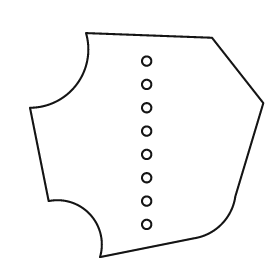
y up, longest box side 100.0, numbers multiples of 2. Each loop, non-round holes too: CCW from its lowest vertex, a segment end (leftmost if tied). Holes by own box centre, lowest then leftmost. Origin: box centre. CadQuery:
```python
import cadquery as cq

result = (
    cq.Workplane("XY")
    .moveTo(-20.0, -48.0)
    .lineTo(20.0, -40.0)
    .threePointArc((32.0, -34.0), (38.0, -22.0))
    .lineTo(50.0, 18.0)
    .lineTo(28.0, 46.0)
    .lineTo(-26.0, 48.0)
    .threePointArc((-30.0, 26.0), (-50.0, 16.0))
    .lineTo(-42.0, -24.0)
    .threePointArc((-24.0, -30.0), (-20.0, -48.0))
    .close()
    .moveTo(0.0, -34.0)
    .circle(2.0)
    .moveTo(0.0, -24.0)
    .circle(2.0)
    .moveTo(0.0, -14.0)
    .circle(2.0)
    .moveTo(0.0, -4.0)
    .circle(2.0)
    .moveTo(0.0, 6.0)
    .circle(2.0)
    .moveTo(0.0, 16.0)
    .circle(2.0)
    .moveTo(0.0, 26.0)
    .circle(2.0)
    .moveTo(0.0, 36.0)
    .circle(2.0)
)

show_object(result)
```